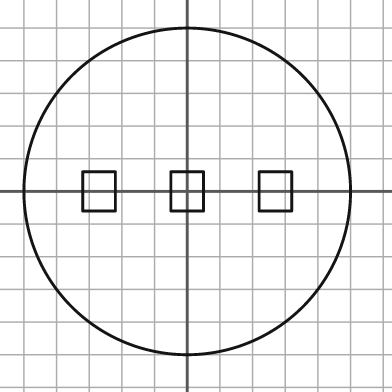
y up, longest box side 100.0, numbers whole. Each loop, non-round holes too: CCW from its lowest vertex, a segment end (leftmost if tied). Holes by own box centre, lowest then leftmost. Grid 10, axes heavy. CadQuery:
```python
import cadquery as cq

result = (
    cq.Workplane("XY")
    .moveTo(0.0, 0.0)
    .circle(50.0)
    .moveTo(-32.0, -6.0)
    .lineTo(-22.0, -6.0)
    .lineTo(-22.0, 6.0)
    .lineTo(-32.0, 6.0)
    .close()
    .moveTo(-5.0, -6.0)
    .lineTo(5.0, -6.0)
    .lineTo(5.0, 6.0)
    .lineTo(-5.0, 6.0)
    .close()
    .moveTo(22.0, -6.0)
    .lineTo(32.0, -6.0)
    .lineTo(32.0, 6.0)
    .lineTo(22.0, 6.0)
    .close()
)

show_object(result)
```